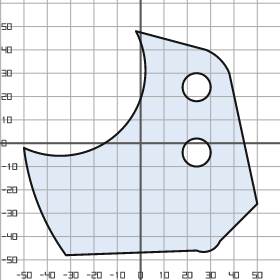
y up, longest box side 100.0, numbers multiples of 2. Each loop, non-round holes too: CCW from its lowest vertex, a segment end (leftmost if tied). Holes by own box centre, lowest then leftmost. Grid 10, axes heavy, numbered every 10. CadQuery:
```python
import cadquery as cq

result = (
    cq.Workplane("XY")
    .moveTo(-32.0, -48.0)
    .lineTo(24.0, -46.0)
    .threePointArc((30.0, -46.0), (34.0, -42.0))
    .lineTo(50.0, -26.0)
    .lineTo(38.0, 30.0)
    .threePointArc((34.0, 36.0), (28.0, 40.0))
    .lineTo(-2.0, 48.0)
    .threePointArc((-8.0, 6.0), (-50.0, -2.0))
    .threePointArc((-44.0, -26.0), (-32.0, -48.0))
    .close()
    .moveTo(24.0, -4.0)
    .circle(6.0)
    .moveTo(24.0, 24.0)
    .circle(6.0)
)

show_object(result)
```